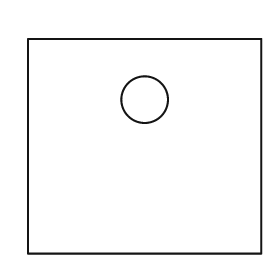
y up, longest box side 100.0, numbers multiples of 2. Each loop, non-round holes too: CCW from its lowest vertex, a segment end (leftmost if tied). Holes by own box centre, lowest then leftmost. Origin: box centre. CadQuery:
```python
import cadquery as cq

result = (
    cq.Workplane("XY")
    .moveTo(-50.0, -46.0)
    .lineTo(50.0, -46.0)
    .lineTo(50.0, 46.0)
    .lineTo(-50.0, 46.0)
    .close()
    .moveTo(0.0, 20.0)
    .circle(10.0)
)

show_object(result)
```